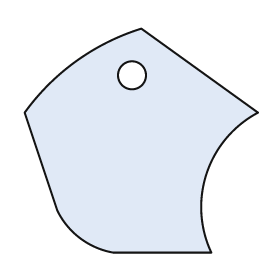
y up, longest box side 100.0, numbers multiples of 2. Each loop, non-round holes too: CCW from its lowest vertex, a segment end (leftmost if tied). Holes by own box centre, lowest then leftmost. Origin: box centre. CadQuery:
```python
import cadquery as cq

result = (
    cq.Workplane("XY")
    .moveTo(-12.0, -48.0)
    .lineTo(30.0, -48.0)
    .threePointArc((28.0, -14.0), (50.0, 12.0))
    .lineTo(0.0, 48.0)
    .threePointArc((-28.0, 34.0), (-50.0, 12.0))
    .lineTo(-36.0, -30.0)
    .threePointArc((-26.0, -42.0), (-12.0, -48.0))
    .close()
    .moveTo(-4.0, 28.0)
    .circle(6.0)
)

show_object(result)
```